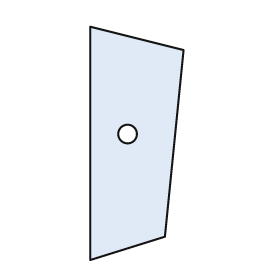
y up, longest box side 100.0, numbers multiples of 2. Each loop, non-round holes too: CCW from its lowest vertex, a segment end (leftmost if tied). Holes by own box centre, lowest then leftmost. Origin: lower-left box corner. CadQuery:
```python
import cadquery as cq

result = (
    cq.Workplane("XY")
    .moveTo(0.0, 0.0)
    .lineTo(32.0, 10.0)
    .lineTo(40.0, 90.0)
    .lineTo(0.0, 100.0)
    .close()
    .moveTo(16.0, 54.0)
    .circle(4.0)
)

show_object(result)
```